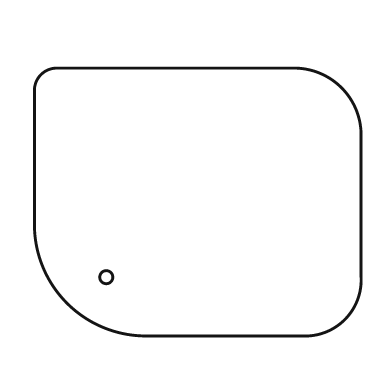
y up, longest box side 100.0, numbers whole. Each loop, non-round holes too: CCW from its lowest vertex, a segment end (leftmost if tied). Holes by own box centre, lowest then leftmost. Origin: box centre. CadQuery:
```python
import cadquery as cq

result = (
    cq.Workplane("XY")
    .moveTo(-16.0, -41.0)
    .lineTo(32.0, -41.0)
    .threePointArc((45.0, -36.0), (50.0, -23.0))
    .lineTo(50.0, 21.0)
    .threePointArc((44.0, 35.0), (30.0, 41.0))
    .lineTo(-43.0, 41.0)
    .threePointArc((-48.0, 39.0), (-50.0, 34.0))
    .lineTo(-50.0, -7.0)
    .threePointArc((-40.0, -31.0), (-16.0, -41.0))
    .close()
    .moveTo(-28.0, -23.0)
    .circle(2.0)
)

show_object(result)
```